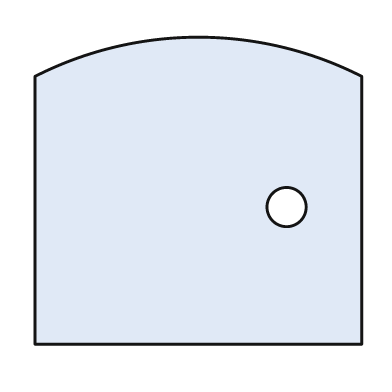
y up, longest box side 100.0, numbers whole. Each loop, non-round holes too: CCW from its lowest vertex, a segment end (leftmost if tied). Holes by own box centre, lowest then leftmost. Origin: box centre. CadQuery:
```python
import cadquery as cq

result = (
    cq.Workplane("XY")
    .moveTo(-50.0, -47.0)
    .lineTo(50.0, -47.0)
    .lineTo(50.0, 35.0)
    .threePointArc((0.0, 47.0), (-50.0, 35.0))
    .close()
    .moveTo(27.0, -5.0)
    .circle(6.0)
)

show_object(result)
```